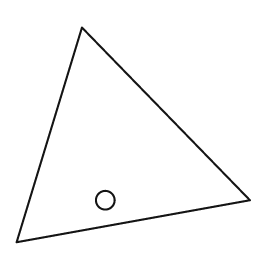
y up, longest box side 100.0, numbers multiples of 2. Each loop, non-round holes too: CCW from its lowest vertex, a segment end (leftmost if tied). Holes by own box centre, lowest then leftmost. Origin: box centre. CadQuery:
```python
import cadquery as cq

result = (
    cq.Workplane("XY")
    .moveTo(-50.0, -46.0)
    .lineTo(50.0, -28.0)
    .lineTo(-22.0, 46.0)
    .close()
    .moveTo(-12.0, -28.0)
    .circle(4.0)
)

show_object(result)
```